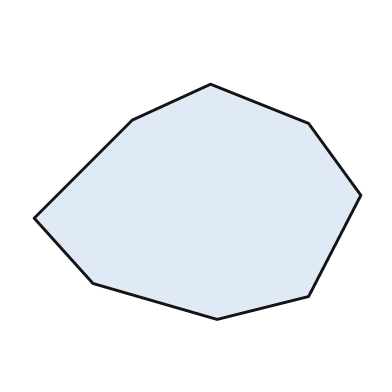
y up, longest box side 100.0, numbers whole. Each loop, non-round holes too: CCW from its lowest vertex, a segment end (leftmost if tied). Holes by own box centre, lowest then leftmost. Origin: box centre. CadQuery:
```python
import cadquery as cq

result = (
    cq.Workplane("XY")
    .moveTo(6.0, -36.0)
    .lineTo(34.0, -29.0)
    .lineTo(50.0, 2.0)
    .lineTo(34.0, 24.0)
    .lineTo(4.0, 36.0)
    .lineTo(-20.0, 25.0)
    .lineTo(-50.0, -5.0)
    .lineTo(-32.0, -25.0)
    .close()
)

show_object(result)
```